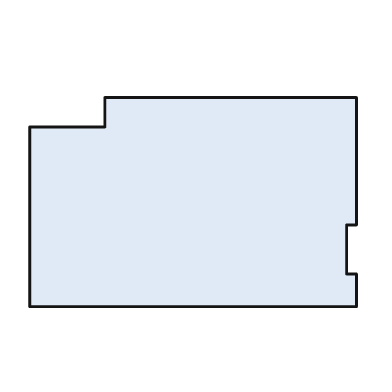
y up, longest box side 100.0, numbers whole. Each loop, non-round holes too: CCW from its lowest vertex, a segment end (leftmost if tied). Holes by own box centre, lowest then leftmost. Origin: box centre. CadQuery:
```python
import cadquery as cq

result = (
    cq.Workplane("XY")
    .moveTo(-50.0, -32.0)
    .lineTo(50.0, -32.0)
    .lineTo(50.0, -22.0)
    .lineTo(47.0, -22.0)
    .lineTo(47.0, -7.0)
    .lineTo(50.0, -7.0)
    .lineTo(50.0, 32.0)
    .lineTo(-27.0, 32.0)
    .lineTo(-27.0, 23.0)
    .lineTo(-50.0, 23.0)
    .close()
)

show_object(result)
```